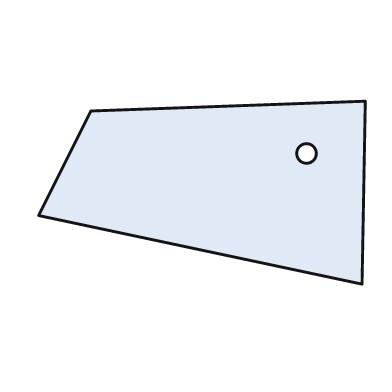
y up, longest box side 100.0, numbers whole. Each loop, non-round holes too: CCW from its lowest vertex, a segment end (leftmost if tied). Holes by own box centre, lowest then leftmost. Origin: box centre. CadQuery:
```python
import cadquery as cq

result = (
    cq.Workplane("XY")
    .moveTo(49.0, -28.0)
    .lineTo(50.0, 28.0)
    .lineTo(-34.0, 25.0)
    .lineTo(-50.0, -7.0)
    .close()
    .moveTo(32.0, 12.0)
    .circle(3.0)
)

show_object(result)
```